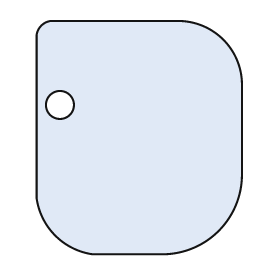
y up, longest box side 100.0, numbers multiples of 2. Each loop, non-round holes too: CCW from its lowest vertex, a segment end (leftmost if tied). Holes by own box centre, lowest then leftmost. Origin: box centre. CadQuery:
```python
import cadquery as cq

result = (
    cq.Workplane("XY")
    .moveTo(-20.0, -50.0)
    .lineTo(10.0, -50.0)
    .threePointArc((34.0, -40.0), (44.0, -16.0))
    .lineTo(44.0, 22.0)
    .threePointArc((36.0, 42.0), (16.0, 50.0))
    .lineTo(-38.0, 50.0)
    .threePointArc((-42.0, 48.0), (-44.0, 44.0))
    .lineTo(-44.0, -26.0)
    .threePointArc((-36.0, -42.0), (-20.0, -50.0))
    .close()
    .moveTo(-34.0, 14.0)
    .circle(6.0)
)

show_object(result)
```